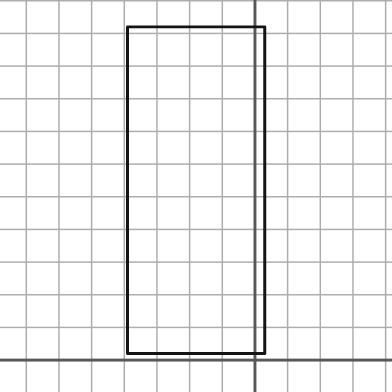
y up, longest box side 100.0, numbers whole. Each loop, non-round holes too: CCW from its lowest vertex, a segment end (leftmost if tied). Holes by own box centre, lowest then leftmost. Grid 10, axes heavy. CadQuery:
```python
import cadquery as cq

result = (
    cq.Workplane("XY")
    .moveTo(-39.0, 2.0)
    .lineTo(3.0, 2.0)
    .lineTo(3.0, 102.0)
    .lineTo(-39.0, 102.0)
    .close()
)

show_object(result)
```